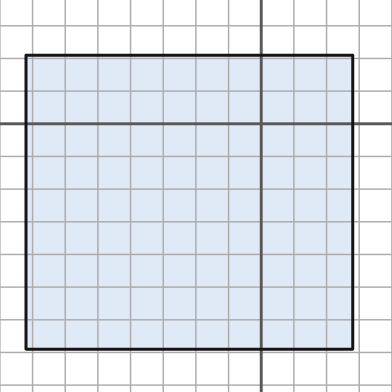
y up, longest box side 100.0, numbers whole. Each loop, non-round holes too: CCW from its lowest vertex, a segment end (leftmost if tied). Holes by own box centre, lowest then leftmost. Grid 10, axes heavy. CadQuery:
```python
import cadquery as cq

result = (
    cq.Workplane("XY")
    .moveTo(-72.0, -69.0)
    .lineTo(28.0, -69.0)
    .lineTo(28.0, 21.0)
    .lineTo(-72.0, 21.0)
    .close()
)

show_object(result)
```